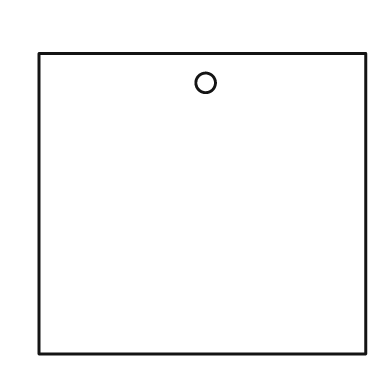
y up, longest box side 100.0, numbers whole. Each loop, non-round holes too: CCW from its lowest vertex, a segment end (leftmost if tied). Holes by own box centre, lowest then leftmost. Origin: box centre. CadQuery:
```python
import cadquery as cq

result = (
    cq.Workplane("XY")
    .moveTo(-50.0, -46.0)
    .lineTo(50.0, -46.0)
    .lineTo(50.0, 46.0)
    .lineTo(-50.0, 46.0)
    .close()
    .moveTo(1.0, 37.0)
    .circle(3.0)
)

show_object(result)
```